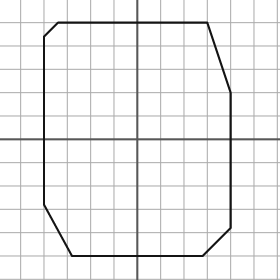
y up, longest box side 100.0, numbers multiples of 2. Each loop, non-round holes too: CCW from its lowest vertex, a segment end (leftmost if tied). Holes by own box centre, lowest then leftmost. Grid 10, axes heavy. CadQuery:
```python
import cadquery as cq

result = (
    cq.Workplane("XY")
    .moveTo(-28.0, -50.0)
    .lineTo(28.0, -50.0)
    .lineTo(40.0, -38.0)
    .lineTo(40.0, 20.0)
    .lineTo(30.0, 50.0)
    .lineTo(-34.0, 50.0)
    .lineTo(-40.0, 44.0)
    .lineTo(-40.0, -28.0)
    .close()
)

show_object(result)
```